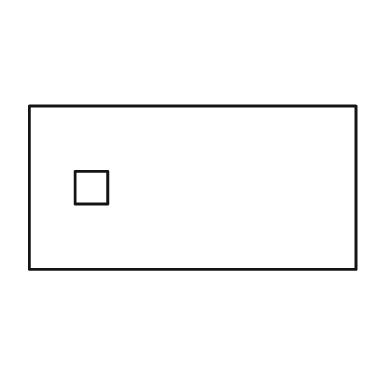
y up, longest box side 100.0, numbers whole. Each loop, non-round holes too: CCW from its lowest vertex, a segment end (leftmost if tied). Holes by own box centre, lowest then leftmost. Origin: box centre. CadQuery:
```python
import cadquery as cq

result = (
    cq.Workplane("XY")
    .moveTo(-50.0, -25.0)
    .lineTo(50.0, -25.0)
    .lineTo(50.0, 25.0)
    .lineTo(-50.0, 25.0)
    .close()
    .moveTo(-36.0, -5.0)
    .lineTo(-26.0, -5.0)
    .lineTo(-26.0, 5.0)
    .lineTo(-36.0, 5.0)
    .close()
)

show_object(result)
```